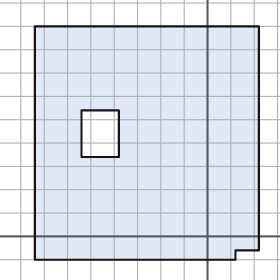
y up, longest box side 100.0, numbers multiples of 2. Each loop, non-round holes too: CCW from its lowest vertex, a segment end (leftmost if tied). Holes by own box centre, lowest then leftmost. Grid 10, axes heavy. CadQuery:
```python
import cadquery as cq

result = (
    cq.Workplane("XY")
    .moveTo(-74.0, -10.0)
    .lineTo(12.0, -10.0)
    .lineTo(12.0, -6.0)
    .lineTo(22.0, -6.0)
    .lineTo(22.0, 90.0)
    .lineTo(-74.0, 90.0)
    .close()
    .moveTo(-54.0, 34.0)
    .lineTo(-38.0, 34.0)
    .lineTo(-38.0, 54.0)
    .lineTo(-54.0, 54.0)
    .close()
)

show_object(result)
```